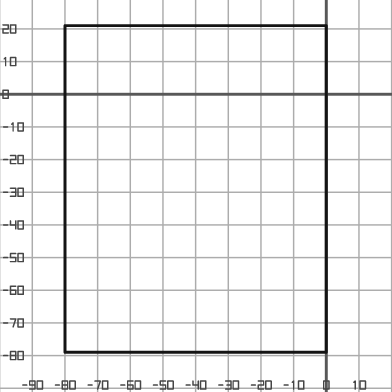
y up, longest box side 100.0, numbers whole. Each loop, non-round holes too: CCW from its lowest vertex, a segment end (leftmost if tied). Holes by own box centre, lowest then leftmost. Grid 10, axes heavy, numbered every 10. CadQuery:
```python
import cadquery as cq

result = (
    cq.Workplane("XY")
    .moveTo(-80.0, -79.0)
    .lineTo(0.0, -79.0)
    .lineTo(0.0, 21.0)
    .lineTo(-80.0, 21.0)
    .close()
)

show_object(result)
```